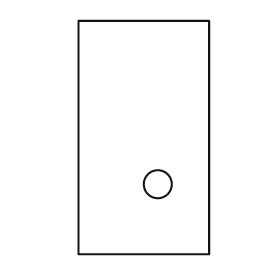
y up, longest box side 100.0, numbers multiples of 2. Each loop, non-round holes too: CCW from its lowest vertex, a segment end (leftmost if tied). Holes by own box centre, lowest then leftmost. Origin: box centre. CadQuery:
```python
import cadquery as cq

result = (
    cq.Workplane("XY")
    .moveTo(-28.0, -50.0)
    .lineTo(28.0, -50.0)
    .lineTo(28.0, 50.0)
    .lineTo(-28.0, 50.0)
    .close()
    .moveTo(6.0, -20.0)
    .circle(6.0)
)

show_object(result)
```